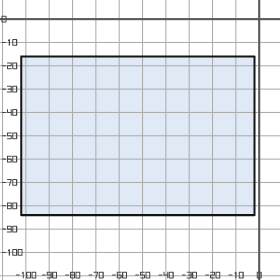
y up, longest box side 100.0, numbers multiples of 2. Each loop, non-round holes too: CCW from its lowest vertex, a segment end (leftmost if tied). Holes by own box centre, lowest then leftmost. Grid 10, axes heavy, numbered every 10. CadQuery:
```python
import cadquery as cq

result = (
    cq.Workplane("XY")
    .moveTo(-102.0, -84.0)
    .lineTo(-2.0, -84.0)
    .lineTo(-2.0, -16.0)
    .lineTo(-102.0, -16.0)
    .close()
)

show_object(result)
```